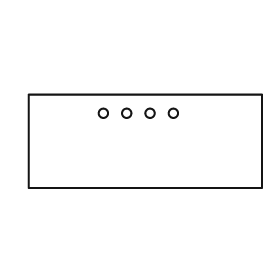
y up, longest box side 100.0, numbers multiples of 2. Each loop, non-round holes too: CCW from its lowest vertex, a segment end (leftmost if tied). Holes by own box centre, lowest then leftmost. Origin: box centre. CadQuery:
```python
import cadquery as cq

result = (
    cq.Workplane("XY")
    .moveTo(-50.0, -20.0)
    .lineTo(50.0, -20.0)
    .lineTo(50.0, 20.0)
    .lineTo(-50.0, 20.0)
    .close()
    .moveTo(-18.0, 12.0)
    .circle(2.0)
    .moveTo(-8.0, 12.0)
    .circle(2.0)
    .moveTo(2.0, 12.0)
    .circle(2.0)
    .moveTo(12.0, 12.0)
    .circle(2.0)
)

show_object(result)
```